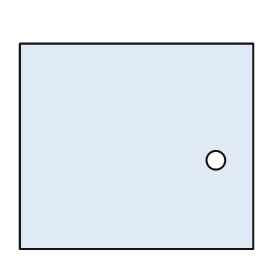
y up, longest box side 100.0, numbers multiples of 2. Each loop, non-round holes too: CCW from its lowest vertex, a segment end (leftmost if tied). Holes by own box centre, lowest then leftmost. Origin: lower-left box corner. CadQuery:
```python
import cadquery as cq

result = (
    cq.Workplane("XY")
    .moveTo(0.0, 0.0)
    .lineTo(100.0, 0.0)
    .lineTo(100.0, 88.0)
    .lineTo(0.0, 88.0)
    .close()
    .moveTo(84.0, 38.0)
    .circle(4.0)
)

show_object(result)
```